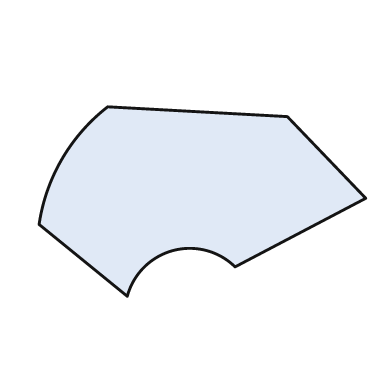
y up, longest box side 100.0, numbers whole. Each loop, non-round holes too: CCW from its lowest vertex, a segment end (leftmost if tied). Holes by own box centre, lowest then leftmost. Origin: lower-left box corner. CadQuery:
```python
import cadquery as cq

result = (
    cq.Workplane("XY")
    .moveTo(27.0, 0.0)
    .threePointArc((41.0, 14.0), (60.0, 9.0))
    .lineTo(100.0, 30.0)
    .lineTo(76.0, 55.0)
    .lineTo(21.0, 58.0)
    .threePointArc((7.0, 42.0), (0.0, 22.0))
    .close()
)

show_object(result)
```